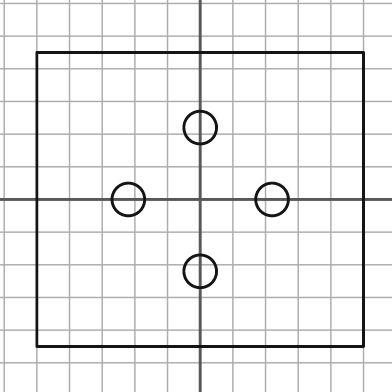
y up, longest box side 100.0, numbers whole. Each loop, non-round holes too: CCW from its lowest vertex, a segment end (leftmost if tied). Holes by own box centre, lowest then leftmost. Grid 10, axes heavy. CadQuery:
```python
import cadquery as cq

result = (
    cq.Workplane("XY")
    .moveTo(-50.0, -45.0)
    .lineTo(50.0, -45.0)
    .lineTo(50.0, 45.0)
    .lineTo(-50.0, 45.0)
    .close()
    .moveTo(0.0, -22.0)
    .circle(5.0)
    .moveTo(-22.0, 0.0)
    .circle(5.0)
    .moveTo(22.0, 0.0)
    .circle(5.0)
    .moveTo(0.0, 22.0)
    .circle(5.0)
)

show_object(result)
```